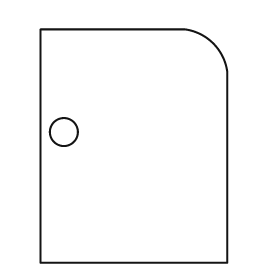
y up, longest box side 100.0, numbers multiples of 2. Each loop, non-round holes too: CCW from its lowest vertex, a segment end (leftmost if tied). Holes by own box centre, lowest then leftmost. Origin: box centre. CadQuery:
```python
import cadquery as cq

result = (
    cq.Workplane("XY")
    .moveTo(-40.0, -50.0)
    .lineTo(40.0, -50.0)
    .lineTo(40.0, 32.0)
    .threePointArc((34.0, 44.0), (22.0, 50.0))
    .lineTo(-40.0, 50.0)
    .close()
    .moveTo(-30.0, 6.0)
    .circle(6.0)
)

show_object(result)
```